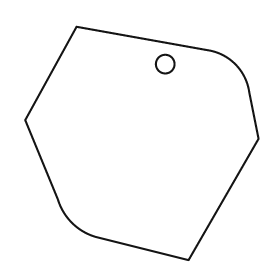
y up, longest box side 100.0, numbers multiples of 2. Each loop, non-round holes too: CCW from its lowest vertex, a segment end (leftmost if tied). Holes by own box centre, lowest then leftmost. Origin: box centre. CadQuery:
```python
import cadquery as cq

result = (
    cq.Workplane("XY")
    .moveTo(20.0, -50.0)
    .lineTo(50.0, 2.0)
    .lineTo(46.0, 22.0)
    .threePointArc((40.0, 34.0), (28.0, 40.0))
    .lineTo(-28.0, 50.0)
    .lineTo(-50.0, 10.0)
    .lineTo(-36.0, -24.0)
    .threePointArc((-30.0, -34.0), (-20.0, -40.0))
    .close()
    .moveTo(10.0, 34.0)
    .circle(4.0)
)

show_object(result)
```